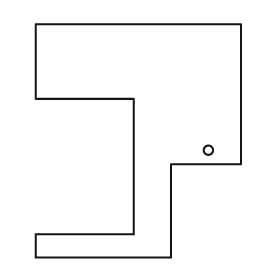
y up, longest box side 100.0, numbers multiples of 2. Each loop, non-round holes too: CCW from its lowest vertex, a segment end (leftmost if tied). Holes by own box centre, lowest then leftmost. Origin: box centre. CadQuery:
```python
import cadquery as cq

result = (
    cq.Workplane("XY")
    .moveTo(-44.0, -50.0)
    .lineTo(14.0, -50.0)
    .lineTo(14.0, -10.0)
    .lineTo(44.0, -10.0)
    .lineTo(44.0, 50.0)
    .lineTo(-44.0, 50.0)
    .lineTo(-44.0, 18.0)
    .lineTo(-2.0, 18.0)
    .lineTo(-2.0, -40.0)
    .lineTo(-44.0, -40.0)
    .close()
    .moveTo(30.0, -4.0)
    .circle(2.0)
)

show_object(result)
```